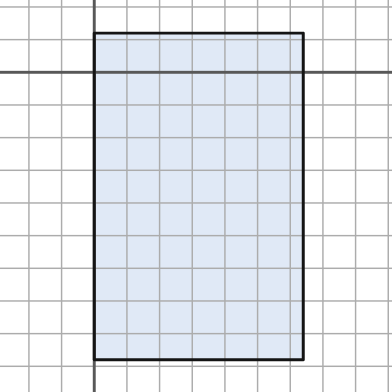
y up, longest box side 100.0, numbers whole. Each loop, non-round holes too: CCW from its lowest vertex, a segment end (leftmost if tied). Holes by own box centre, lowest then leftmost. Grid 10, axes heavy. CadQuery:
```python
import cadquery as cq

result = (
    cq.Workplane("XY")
    .moveTo(0.0, -88.0)
    .lineTo(64.0, -88.0)
    .lineTo(64.0, 12.0)
    .lineTo(0.0, 12.0)
    .close()
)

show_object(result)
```